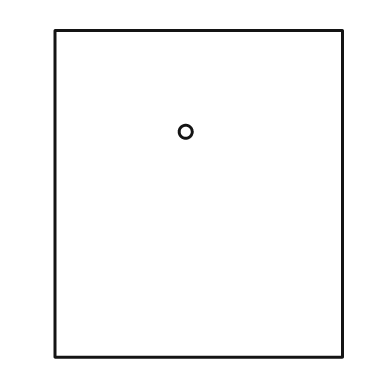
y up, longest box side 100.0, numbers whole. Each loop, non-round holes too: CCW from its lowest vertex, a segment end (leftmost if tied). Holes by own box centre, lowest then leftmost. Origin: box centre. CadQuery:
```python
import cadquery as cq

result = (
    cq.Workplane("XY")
    .moveTo(-44.0, -50.0)
    .lineTo(44.0, -50.0)
    .lineTo(44.0, 50.0)
    .lineTo(-44.0, 50.0)
    .close()
    .moveTo(-4.0, 19.0)
    .circle(2.0)
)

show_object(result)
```